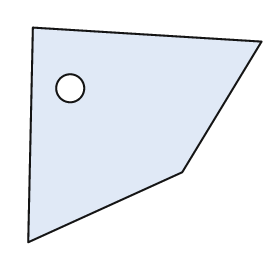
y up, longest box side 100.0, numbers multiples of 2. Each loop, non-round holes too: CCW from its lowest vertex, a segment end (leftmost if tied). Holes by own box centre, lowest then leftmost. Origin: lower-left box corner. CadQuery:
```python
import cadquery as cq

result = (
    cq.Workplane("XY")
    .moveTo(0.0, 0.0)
    .lineTo(66.0, 30.0)
    .lineTo(100.0, 86.0)
    .lineTo(2.0, 92.0)
    .close()
    .moveTo(18.0, 66.0)
    .circle(6.0)
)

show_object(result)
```